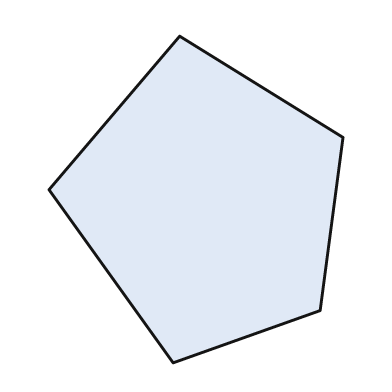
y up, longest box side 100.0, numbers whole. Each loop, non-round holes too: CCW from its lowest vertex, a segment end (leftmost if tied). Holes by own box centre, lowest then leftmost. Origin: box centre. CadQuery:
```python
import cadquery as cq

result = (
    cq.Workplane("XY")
    .moveTo(-7.0, -50.0)
    .lineTo(38.0, -34.0)
    .lineTo(45.0, 19.0)
    .lineTo(-5.0, 50.0)
    .lineTo(-45.0, 3.0)
    .close()
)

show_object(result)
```